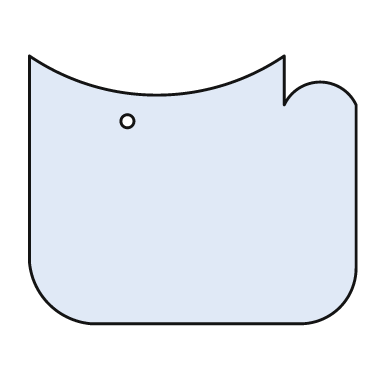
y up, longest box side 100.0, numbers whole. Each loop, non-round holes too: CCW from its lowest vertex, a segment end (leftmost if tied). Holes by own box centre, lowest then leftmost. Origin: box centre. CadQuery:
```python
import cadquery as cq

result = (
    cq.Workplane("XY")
    .moveTo(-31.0, -41.0)
    .lineTo(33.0, -41.0)
    .threePointArc((45.0, -36.0), (50.0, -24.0))
    .lineTo(50.0, 26.0)
    .threePointArc((39.0, 33.0), (28.0, 26.0))
    .lineTo(28.0, 41.0)
    .threePointArc((-11.0, 29.0), (-50.0, 41.0))
    .lineTo(-50.0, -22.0)
    .threePointArc((-44.0, -35.0), (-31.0, -41.0))
    .close()
    .moveTo(-20.0, 21.0)
    .circle(2.0)
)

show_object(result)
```